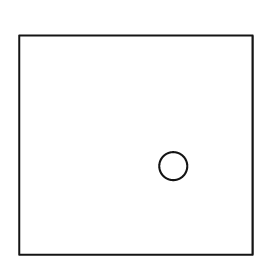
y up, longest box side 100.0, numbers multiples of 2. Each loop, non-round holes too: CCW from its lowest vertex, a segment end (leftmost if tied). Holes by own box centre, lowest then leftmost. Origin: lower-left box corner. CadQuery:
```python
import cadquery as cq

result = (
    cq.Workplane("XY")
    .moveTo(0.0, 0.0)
    .lineTo(100.0, 0.0)
    .lineTo(100.0, 94.0)
    .lineTo(0.0, 94.0)
    .close()
    .moveTo(66.0, 38.0)
    .circle(6.0)
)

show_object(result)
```